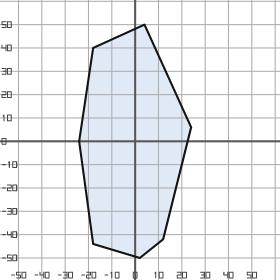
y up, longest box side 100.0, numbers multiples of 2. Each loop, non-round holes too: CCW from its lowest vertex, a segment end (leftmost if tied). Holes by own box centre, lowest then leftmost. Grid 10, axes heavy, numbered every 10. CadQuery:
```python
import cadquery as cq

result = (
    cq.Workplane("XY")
    .moveTo(2.0, -50.0)
    .lineTo(12.0, -42.0)
    .lineTo(24.0, 6.0)
    .lineTo(4.0, 50.0)
    .lineTo(-18.0, 40.0)
    .lineTo(-24.0, 0.0)
    .lineTo(-18.0, -44.0)
    .close()
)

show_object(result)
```